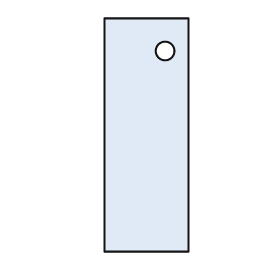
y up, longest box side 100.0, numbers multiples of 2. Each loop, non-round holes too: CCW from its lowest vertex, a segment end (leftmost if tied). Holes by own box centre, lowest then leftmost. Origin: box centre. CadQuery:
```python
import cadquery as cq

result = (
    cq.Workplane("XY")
    .moveTo(-18.0, -50.0)
    .lineTo(18.0, -50.0)
    .lineTo(18.0, 50.0)
    .lineTo(-18.0, 50.0)
    .close()
    .moveTo(8.0, 36.0)
    .circle(4.0)
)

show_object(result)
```